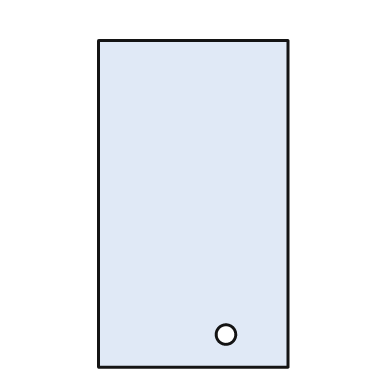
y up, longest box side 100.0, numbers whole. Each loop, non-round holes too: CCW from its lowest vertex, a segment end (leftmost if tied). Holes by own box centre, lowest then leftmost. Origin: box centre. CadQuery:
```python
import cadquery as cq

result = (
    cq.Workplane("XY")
    .moveTo(-29.0, -50.0)
    .lineTo(29.0, -50.0)
    .lineTo(29.0, 50.0)
    .lineTo(-29.0, 50.0)
    .close()
    .moveTo(10.0, -40.0)
    .circle(3.0)
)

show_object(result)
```